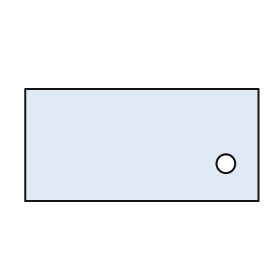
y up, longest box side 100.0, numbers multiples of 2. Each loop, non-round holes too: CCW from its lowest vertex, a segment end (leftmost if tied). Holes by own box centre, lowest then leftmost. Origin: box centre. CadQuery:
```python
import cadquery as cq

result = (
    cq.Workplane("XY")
    .moveTo(-50.0, -24.0)
    .lineTo(50.0, -24.0)
    .lineTo(50.0, 24.0)
    .lineTo(-50.0, 24.0)
    .close()
    .moveTo(36.0, -8.0)
    .circle(4.0)
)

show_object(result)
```